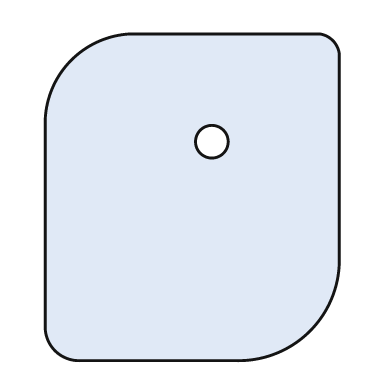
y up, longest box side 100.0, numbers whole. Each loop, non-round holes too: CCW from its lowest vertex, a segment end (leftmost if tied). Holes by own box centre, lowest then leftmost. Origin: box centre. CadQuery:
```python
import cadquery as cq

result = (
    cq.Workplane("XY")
    .moveTo(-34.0, -50.0)
    .lineTo(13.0, -50.0)
    .threePointArc((36.0, -41.0), (45.0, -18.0))
    .lineTo(45.0, 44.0)
    .threePointArc((43.0, 48.0), (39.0, 50.0))
    .lineTo(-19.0, 50.0)
    .threePointArc((-37.0, 42.0), (-45.0, 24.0))
    .lineTo(-45.0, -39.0)
    .threePointArc((-42.0, -47.0), (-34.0, -50.0))
    .close()
    .moveTo(6.0, 17.0)
    .circle(5.0)
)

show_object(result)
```